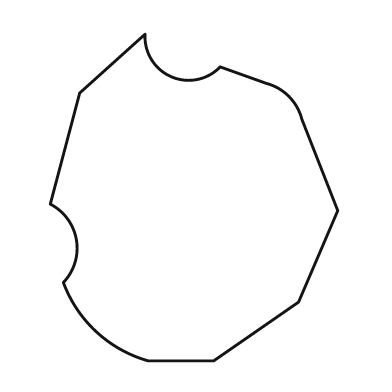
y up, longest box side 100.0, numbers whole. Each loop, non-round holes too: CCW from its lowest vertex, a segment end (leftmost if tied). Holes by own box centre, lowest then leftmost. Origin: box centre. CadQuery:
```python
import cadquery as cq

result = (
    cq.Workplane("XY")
    .moveTo(-14.0, -50.0)
    .lineTo(6.0, -50.0)
    .lineTo(32.0, -32.0)
    .lineTo(44.0, -4.0)
    .lineTo(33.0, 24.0)
    .threePointArc((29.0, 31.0), (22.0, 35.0))
    .lineTo(8.0, 40.0)
    .threePointArc((-7.0, 37.0), (-15.0, 50.0))
    .lineTo(-35.0, 32.0)
    .lineTo(-44.0, -2.0)
    .threePointArc((-36.0, -13.0), (-40.0, -26.0))
    .threePointArc((-30.0, -41.0), (-14.0, -50.0))
    .close()
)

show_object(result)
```